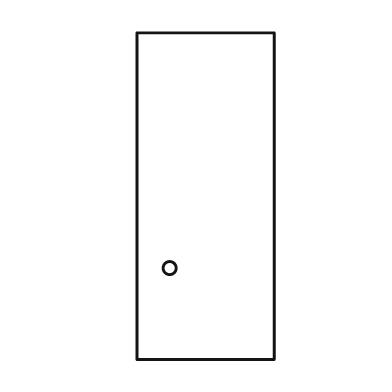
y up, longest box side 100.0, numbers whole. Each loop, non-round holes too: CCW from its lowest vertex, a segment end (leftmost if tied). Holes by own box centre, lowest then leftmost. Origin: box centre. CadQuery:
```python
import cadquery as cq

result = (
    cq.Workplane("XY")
    .moveTo(-21.0, -50.0)
    .lineTo(21.0, -50.0)
    .lineTo(21.0, 50.0)
    .lineTo(-21.0, 50.0)
    .close()
    .moveTo(-11.0, -22.0)
    .circle(2.0)
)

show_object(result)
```